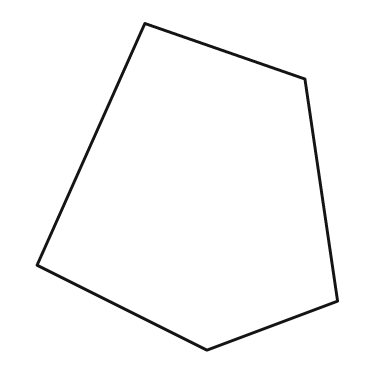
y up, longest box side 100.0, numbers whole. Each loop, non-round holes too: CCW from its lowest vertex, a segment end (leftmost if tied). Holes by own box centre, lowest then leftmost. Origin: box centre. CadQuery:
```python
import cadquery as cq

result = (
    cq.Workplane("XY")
    .moveTo(6.0, -50.0)
    .lineTo(46.0, -35.0)
    .lineTo(36.0, 33.0)
    .lineTo(-13.0, 50.0)
    .lineTo(-46.0, -24.0)
    .close()
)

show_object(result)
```